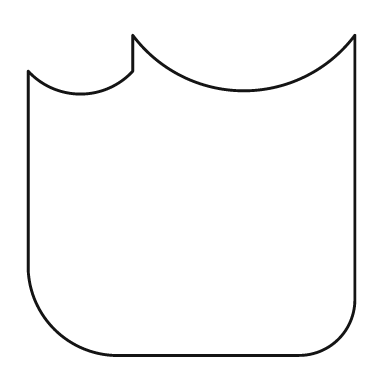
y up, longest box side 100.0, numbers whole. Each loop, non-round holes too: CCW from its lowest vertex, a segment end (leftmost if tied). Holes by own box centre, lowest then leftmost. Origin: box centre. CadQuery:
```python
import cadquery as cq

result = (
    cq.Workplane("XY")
    .moveTo(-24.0, -49.0)
    .lineTo(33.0, -49.0)
    .threePointArc((45.0, -44.0), (50.0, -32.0))
    .lineTo(50.0, 49.0)
    .threePointArc((16.0, 32.0), (-18.0, 49.0))
    .lineTo(-18.0, 38.0)
    .threePointArc((-34.0, 31.0), (-50.0, 38.0))
    .lineTo(-50.0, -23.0)
    .threePointArc((-42.0, -41.0), (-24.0, -49.0))
    .close()
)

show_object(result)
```